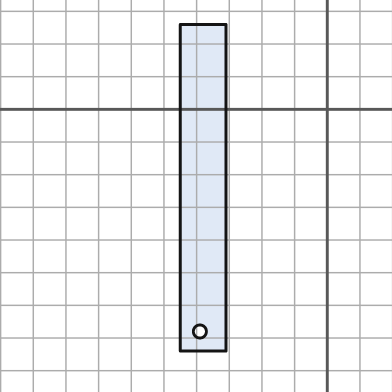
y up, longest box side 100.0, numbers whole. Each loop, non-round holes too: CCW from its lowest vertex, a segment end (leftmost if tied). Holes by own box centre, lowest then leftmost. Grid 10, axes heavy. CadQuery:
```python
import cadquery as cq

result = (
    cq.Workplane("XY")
    .moveTo(-45.0, -74.0)
    .lineTo(-31.0, -74.0)
    .lineTo(-31.0, 26.0)
    .lineTo(-45.0, 26.0)
    .close()
    .moveTo(-39.0, -68.0)
    .circle(2.0)
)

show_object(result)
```